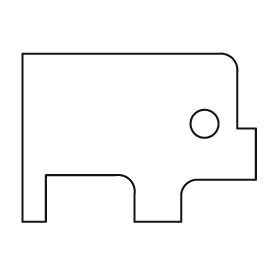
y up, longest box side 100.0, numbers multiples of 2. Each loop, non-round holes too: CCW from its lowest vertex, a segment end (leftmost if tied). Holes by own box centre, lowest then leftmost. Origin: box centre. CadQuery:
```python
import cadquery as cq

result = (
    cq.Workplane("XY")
    .moveTo(-50.0, -36.0)
    .lineTo(-40.0, -36.0)
    .lineTo(-40.0, -16.0)
    .lineTo(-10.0, -16.0)
    .threePointArc((-4.0, -18.0), (-2.0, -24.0))
    .lineTo(-2.0, -36.0)
    .lineTo(18.0, -36.0)
    .lineTo(18.0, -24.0)
    .threePointArc((20.0, -20.0), (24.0, -18.0))
    .lineTo(50.0, -18.0)
    .lineTo(50.0, 4.0)
    .lineTo(42.0, 4.0)
    .lineTo(42.0, 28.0)
    .threePointArc((40.0, 34.0), (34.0, 36.0))
    .lineTo(-50.0, 36.0)
    .close()
    .moveTo(28.0, 6.0)
    .circle(6.0)
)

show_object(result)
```